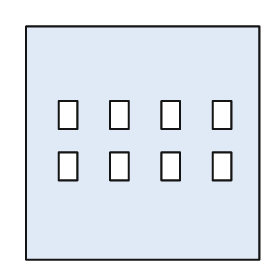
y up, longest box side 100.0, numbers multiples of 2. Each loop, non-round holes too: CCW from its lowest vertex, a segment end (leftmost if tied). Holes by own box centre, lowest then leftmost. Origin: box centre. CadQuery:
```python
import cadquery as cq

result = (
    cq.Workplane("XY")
    .moveTo(-50.0, -50.0)
    .lineTo(50.0, -50.0)
    .lineTo(50.0, 50.0)
    .lineTo(-50.0, 50.0)
    .close()
    .moveTo(-36.0, -16.0)
    .lineTo(-28.0, -16.0)
    .lineTo(-28.0, -4.0)
    .lineTo(-36.0, -4.0)
    .close()
    .moveTo(-14.0, -16.0)
    .lineTo(-6.0, -16.0)
    .lineTo(-6.0, -4.0)
    .lineTo(-14.0, -4.0)
    .close()
    .moveTo(8.0, -16.0)
    .lineTo(16.0, -16.0)
    .lineTo(16.0, -4.0)
    .lineTo(8.0, -4.0)
    .close()
    .moveTo(30.0, -16.0)
    .lineTo(38.0, -16.0)
    .lineTo(38.0, -4.0)
    .lineTo(30.0, -4.0)
    .close()
    .moveTo(-36.0, 6.0)
    .lineTo(-28.0, 6.0)
    .lineTo(-28.0, 18.0)
    .lineTo(-36.0, 18.0)
    .close()
    .moveTo(-14.0, 6.0)
    .lineTo(-6.0, 6.0)
    .lineTo(-6.0, 18.0)
    .lineTo(-14.0, 18.0)
    .close()
    .moveTo(8.0, 6.0)
    .lineTo(16.0, 6.0)
    .lineTo(16.0, 18.0)
    .lineTo(8.0, 18.0)
    .close()
    .moveTo(30.0, 6.0)
    .lineTo(38.0, 6.0)
    .lineTo(38.0, 18.0)
    .lineTo(30.0, 18.0)
    .close()
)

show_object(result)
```